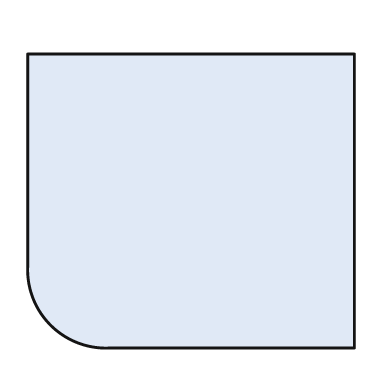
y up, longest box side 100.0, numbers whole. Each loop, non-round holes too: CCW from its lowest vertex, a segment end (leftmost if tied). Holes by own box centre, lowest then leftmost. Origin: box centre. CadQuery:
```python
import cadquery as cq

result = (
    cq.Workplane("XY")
    .moveTo(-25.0, -45.0)
    .lineTo(50.0, -45.0)
    .lineTo(50.0, 45.0)
    .lineTo(-50.0, 45.0)
    .lineTo(-50.0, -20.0)
    .threePointArc((-43.0, -38.0), (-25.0, -45.0))
    .close()
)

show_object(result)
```